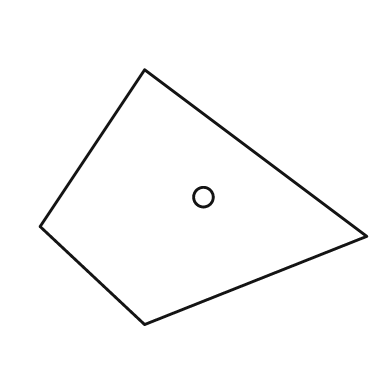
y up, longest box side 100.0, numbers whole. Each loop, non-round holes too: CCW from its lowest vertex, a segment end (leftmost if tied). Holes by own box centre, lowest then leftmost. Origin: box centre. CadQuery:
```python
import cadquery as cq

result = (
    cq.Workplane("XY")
    .moveTo(-18.0, -39.0)
    .lineTo(50.0, -12.0)
    .lineTo(-18.0, 39.0)
    .lineTo(-50.0, -9.0)
    .close()
    .moveTo(0.0, 0.0)
    .circle(3.0)
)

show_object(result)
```